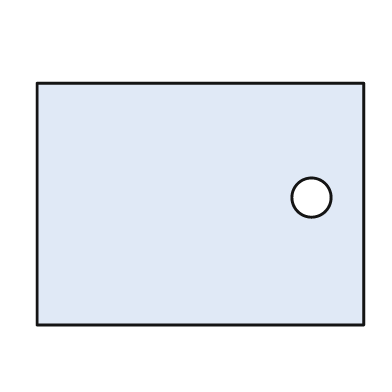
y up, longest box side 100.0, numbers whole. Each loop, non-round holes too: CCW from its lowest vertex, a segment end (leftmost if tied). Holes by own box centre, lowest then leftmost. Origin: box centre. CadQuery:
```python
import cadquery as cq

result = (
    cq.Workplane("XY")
    .moveTo(-50.0, -37.0)
    .lineTo(50.0, -37.0)
    .lineTo(50.0, 37.0)
    .lineTo(-50.0, 37.0)
    .close()
    .moveTo(34.0, 2.0)
    .circle(6.0)
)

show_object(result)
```